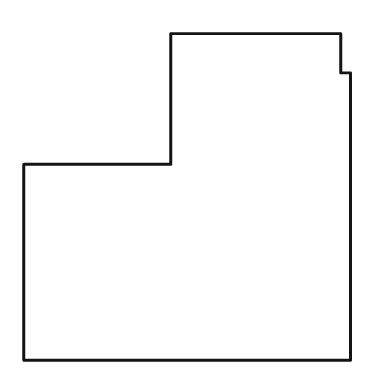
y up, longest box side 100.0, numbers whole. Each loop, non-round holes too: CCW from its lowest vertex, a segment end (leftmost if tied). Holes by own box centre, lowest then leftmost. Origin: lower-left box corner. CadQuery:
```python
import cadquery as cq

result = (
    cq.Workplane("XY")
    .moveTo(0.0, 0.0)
    .lineTo(100.0, 0.0)
    .lineTo(100.0, 88.0)
    .lineTo(97.0, 88.0)
    .lineTo(97.0, 100.0)
    .lineTo(45.0, 100.0)
    .lineTo(45.0, 60.0)
    .lineTo(0.0, 60.0)
    .close()
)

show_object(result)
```